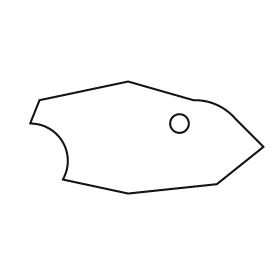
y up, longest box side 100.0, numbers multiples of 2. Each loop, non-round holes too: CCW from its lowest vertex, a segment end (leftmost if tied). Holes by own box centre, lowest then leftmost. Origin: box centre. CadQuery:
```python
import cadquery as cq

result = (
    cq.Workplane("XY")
    .moveTo(-8.0, -24.0)
    .lineTo(30.0, -20.0)
    .lineTo(50.0, -4.0)
    .lineTo(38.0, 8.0)
    .threePointArc((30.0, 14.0), (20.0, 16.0))
    .lineTo(-8.0, 24.0)
    .lineTo(-46.0, 16.0)
    .lineTo(-50.0, 6.0)
    .threePointArc((-36.0, -2.0), (-36.0, -18.0))
    .close()
    .moveTo(14.0, 6.0)
    .circle(4.0)
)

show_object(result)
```